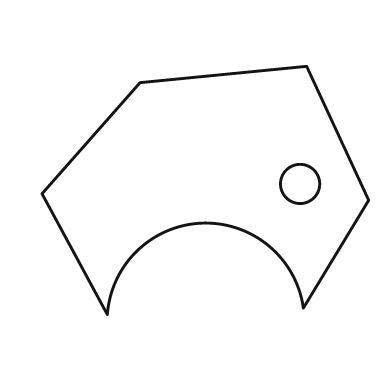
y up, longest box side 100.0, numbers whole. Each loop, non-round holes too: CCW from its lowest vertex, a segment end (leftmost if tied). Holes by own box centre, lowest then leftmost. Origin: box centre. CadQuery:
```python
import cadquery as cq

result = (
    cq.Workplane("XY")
    .moveTo(-30.0, -38.0)
    .threePointArc((-1.0, -10.0), (30.0, -36.0))
    .lineTo(50.0, -3.0)
    .lineTo(31.0, 38.0)
    .lineTo(-20.0, 33.0)
    .lineTo(-50.0, -1.0)
    .close()
    .moveTo(29.0, 2.0)
    .circle(6.0)
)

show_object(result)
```